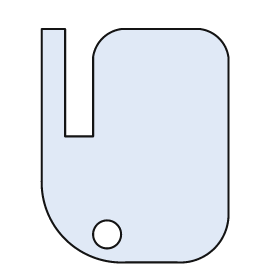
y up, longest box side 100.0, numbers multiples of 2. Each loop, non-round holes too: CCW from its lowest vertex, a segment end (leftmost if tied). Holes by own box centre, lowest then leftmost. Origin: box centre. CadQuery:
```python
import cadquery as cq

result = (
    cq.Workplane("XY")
    .moveTo(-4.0, -50.0)
    .lineTo(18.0, -50.0)
    .threePointArc((34.0, -44.0), (40.0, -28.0))
    .lineTo(40.0, 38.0)
    .threePointArc((36.0, 46.0), (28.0, 50.0))
    .lineTo(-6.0, 50.0)
    .threePointArc((-14.0, 46.0), (-18.0, 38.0))
    .lineTo(-18.0, 4.0)
    .lineTo(-30.0, 4.0)
    .lineTo(-30.0, 50.0)
    .lineTo(-40.0, 50.0)
    .lineTo(-40.0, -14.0)
    .threePointArc((-30.0, -40.0), (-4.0, -50.0))
    .close()
    .moveTo(-12.0, -38.0)
    .circle(6.0)
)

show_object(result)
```